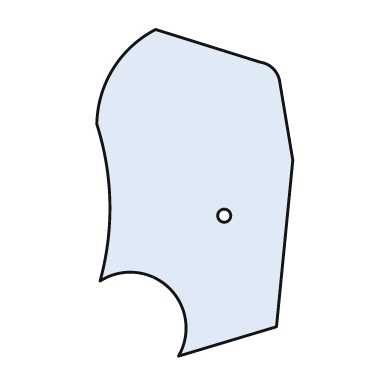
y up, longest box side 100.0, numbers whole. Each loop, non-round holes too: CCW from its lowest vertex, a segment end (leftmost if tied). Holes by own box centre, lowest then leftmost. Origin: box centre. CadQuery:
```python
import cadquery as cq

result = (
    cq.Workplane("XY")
    .moveTo(-5.0, -50.0)
    .lineTo(25.0, -41.0)
    .lineTo(30.0, 10.0)
    .lineTo(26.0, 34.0)
    .threePointArc((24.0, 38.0), (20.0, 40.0))
    .lineTo(-12.0, 50.0)
    .threePointArc((-25.0, 38.0), (-30.0, 21.0))
    .threePointArc((-26.0, -3.0), (-29.0, -27.0))
    .threePointArc((-8.0, -29.0), (-5.0, -50.0))
    .close()
    .moveTo(9.0, -7.0)
    .circle(2.0)
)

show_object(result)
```